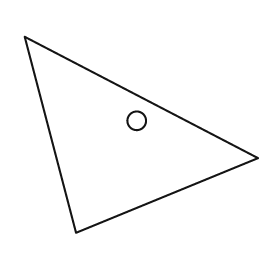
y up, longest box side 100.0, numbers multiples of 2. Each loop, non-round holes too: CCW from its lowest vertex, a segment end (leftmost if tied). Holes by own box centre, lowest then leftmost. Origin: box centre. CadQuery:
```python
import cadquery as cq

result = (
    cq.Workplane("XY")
    .moveTo(-28.0, -42.0)
    .lineTo(50.0, -10.0)
    .lineTo(-50.0, 42.0)
    .close()
    .moveTo(-2.0, 6.0)
    .circle(4.0)
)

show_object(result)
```